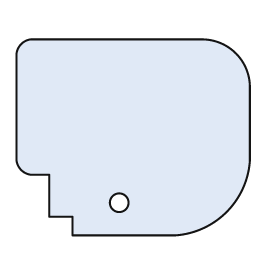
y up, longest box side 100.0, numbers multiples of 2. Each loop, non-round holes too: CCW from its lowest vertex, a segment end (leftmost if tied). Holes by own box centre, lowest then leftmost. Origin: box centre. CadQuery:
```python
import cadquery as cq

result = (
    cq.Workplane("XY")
    .moveTo(-26.0, -42.0)
    .lineTo(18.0, -42.0)
    .threePointArc((40.0, -32.0), (50.0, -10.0))
    .lineTo(50.0, 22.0)
    .threePointArc((44.0, 36.0), (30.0, 42.0))
    .lineTo(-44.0, 42.0)
    .threePointArc((-48.0, 40.0), (-50.0, 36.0))
    .lineTo(-50.0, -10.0)
    .threePointArc((-48.0, -14.0), (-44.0, -16.0))
    .lineTo(-36.0, -16.0)
    .lineTo(-36.0, -34.0)
    .lineTo(-26.0, -34.0)
    .close()
    .moveTo(-6.0, -28.0)
    .circle(4.0)
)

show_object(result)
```